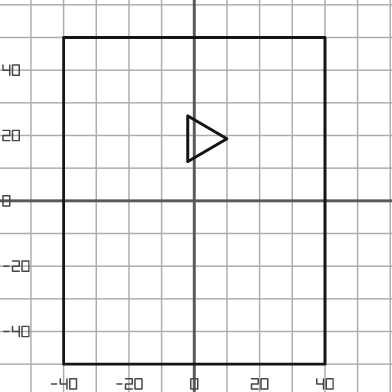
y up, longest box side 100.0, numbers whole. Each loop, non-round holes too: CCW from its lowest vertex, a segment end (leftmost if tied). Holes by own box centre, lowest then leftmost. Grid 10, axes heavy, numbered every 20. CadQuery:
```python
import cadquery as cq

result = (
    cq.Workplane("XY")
    .moveTo(-40.0, -50.0)
    .lineTo(40.0, -50.0)
    .lineTo(40.0, 50.0)
    .lineTo(-40.0, 50.0)
    .close()
    .moveTo(-2.0, 12.0)
    .lineTo(10.0, 19.0)
    .lineTo(-2.0, 26.0)
    .close()
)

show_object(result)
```